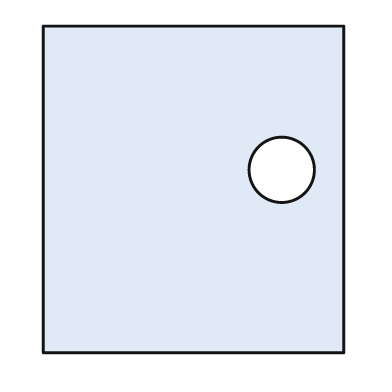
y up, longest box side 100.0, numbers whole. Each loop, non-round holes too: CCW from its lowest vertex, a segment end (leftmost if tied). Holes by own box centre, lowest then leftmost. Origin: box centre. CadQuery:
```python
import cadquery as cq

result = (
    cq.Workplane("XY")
    .moveTo(-46.0, -50.0)
    .lineTo(46.0, -50.0)
    .lineTo(46.0, 50.0)
    .lineTo(-46.0, 50.0)
    .close()
    .moveTo(27.0, 6.0)
    .circle(10.0)
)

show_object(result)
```